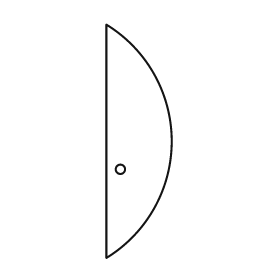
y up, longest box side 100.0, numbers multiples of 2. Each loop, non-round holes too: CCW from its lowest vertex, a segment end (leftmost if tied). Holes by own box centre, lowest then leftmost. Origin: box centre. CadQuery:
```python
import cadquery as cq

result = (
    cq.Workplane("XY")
    .moveTo(-14.0, -50.0)
    .threePointArc((14.0, 0.0), (-14.0, 50.0))
    .close()
    .moveTo(-8.0, -12.0)
    .circle(2.0)
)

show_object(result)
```